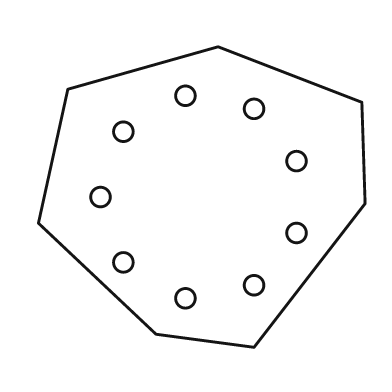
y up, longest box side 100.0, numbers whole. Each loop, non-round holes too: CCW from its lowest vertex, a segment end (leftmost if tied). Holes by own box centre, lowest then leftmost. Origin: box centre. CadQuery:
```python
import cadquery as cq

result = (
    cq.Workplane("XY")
    .moveTo(16.0, -46.0)
    .lineTo(50.0, -2.0)
    .lineTo(49.0, 29.0)
    .lineTo(5.0, 46.0)
    .lineTo(-41.0, 33.0)
    .lineTo(-50.0, -8.0)
    .lineTo(-14.0, -42.0)
    .close()
    .moveTo(-5.0, -31.0)
    .circle(3.0)
    .moveTo(16.0, -27.0)
    .circle(3.0)
    .moveTo(-24.0, -20.0)
    .circle(3.0)
    .moveTo(29.0, -11.0)
    .circle(3.0)
    .moveTo(-31.0, 0.0)
    .circle(3.0)
    .moveTo(29.0, 11.0)
    .circle(3.0)
    .moveTo(-24.0, 20.0)
    .circle(3.0)
    .moveTo(16.0, 27.0)
    .circle(3.0)
    .moveTo(-5.0, 31.0)
    .circle(3.0)
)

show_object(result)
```